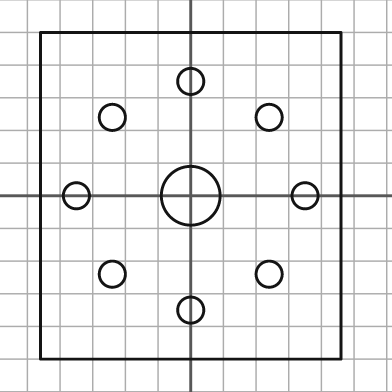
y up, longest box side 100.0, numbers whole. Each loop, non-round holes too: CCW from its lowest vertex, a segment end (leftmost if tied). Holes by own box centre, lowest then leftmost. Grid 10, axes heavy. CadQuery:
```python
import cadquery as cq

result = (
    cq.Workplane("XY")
    .moveTo(-46.0, -50.0)
    .lineTo(46.0, -50.0)
    .lineTo(46.0, 50.0)
    .lineTo(-46.0, 50.0)
    .close()
    .moveTo(0.0, -35.0)
    .circle(4.0)
    .moveTo(-24.0, -24.0)
    .circle(4.0)
    .moveTo(24.0, -24.0)
    .circle(4.0)
    .moveTo(-35.0, 0.0)
    .circle(4.0)
    .moveTo(0.0, 0.0)
    .circle(9.0)
    .moveTo(35.0, 0.0)
    .circle(4.0)
    .moveTo(-24.0, 24.0)
    .circle(4.0)
    .moveTo(24.0, 24.0)
    .circle(4.0)
    .moveTo(0.0, 35.0)
    .circle(4.0)
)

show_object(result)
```